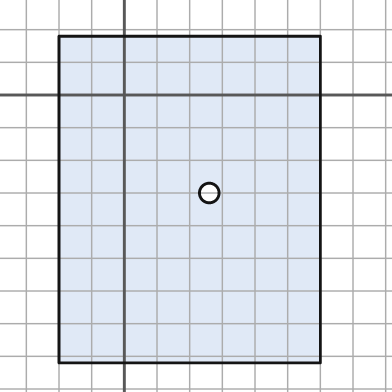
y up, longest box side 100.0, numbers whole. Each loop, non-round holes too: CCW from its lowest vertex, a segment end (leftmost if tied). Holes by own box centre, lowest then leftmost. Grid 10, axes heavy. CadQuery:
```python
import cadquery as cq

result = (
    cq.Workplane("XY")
    .moveTo(-20.0, -82.0)
    .lineTo(60.0, -82.0)
    .lineTo(60.0, 18.0)
    .lineTo(-20.0, 18.0)
    .close()
    .moveTo(26.0, -30.0)
    .circle(3.0)
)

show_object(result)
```